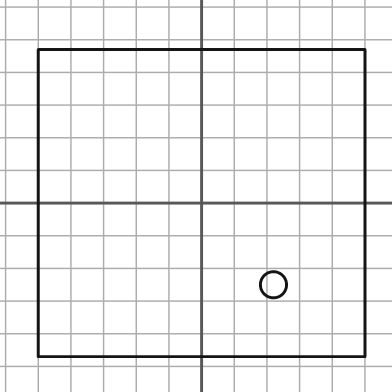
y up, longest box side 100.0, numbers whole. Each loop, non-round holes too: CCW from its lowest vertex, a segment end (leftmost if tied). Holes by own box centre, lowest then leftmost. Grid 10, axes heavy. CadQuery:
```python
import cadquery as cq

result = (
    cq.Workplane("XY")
    .moveTo(-50.0, -47.0)
    .lineTo(50.0, -47.0)
    .lineTo(50.0, 47.0)
    .lineTo(-50.0, 47.0)
    .close()
    .moveTo(22.0, -25.0)
    .circle(4.0)
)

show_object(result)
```